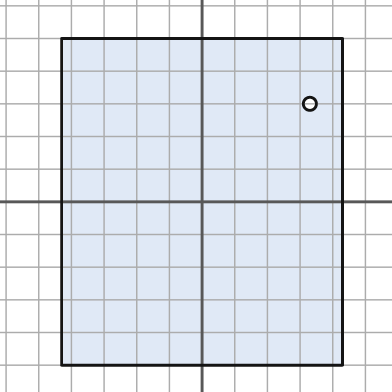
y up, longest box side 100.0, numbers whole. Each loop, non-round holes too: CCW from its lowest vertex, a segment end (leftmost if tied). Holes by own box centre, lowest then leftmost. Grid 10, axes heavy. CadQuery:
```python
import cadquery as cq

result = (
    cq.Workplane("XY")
    .moveTo(-43.0, -50.0)
    .lineTo(43.0, -50.0)
    .lineTo(43.0, 50.0)
    .lineTo(-43.0, 50.0)
    .close()
    .moveTo(33.0, 30.0)
    .circle(2.0)
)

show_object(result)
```